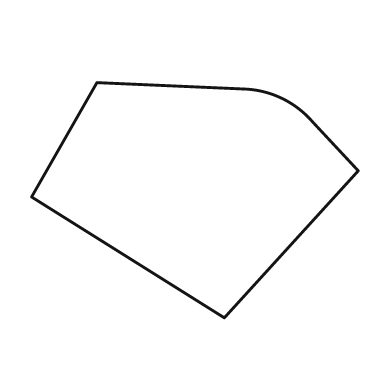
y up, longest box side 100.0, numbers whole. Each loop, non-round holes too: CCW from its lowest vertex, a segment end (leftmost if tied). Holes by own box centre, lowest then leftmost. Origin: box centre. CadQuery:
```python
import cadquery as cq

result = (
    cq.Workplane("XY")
    .moveTo(9.0, -36.0)
    .lineTo(50.0, 9.0)
    .lineTo(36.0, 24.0)
    .threePointArc((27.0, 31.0), (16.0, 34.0))
    .lineTo(-30.0, 36.0)
    .lineTo(-50.0, 1.0)
    .close()
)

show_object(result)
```